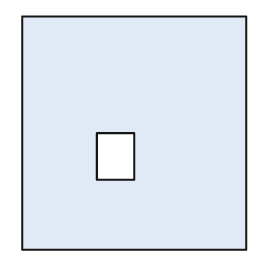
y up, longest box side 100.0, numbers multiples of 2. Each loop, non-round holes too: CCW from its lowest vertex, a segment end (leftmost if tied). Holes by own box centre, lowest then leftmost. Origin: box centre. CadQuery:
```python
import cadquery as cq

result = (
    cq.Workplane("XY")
    .moveTo(-48.0, -50.0)
    .lineTo(48.0, -50.0)
    .lineTo(48.0, 50.0)
    .lineTo(-48.0, 50.0)
    .close()
    .moveTo(-16.0, -20.0)
    .lineTo(0.0, -20.0)
    .lineTo(0.0, 0.0)
    .lineTo(-16.0, 0.0)
    .close()
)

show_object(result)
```